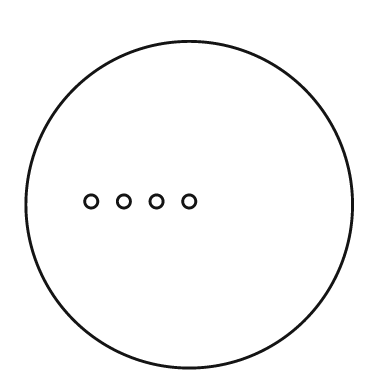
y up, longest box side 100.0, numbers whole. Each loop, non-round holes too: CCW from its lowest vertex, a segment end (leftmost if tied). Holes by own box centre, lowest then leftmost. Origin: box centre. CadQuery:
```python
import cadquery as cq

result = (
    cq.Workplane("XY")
    .moveTo(0.0, 0.0)
    .circle(50.0)
    .moveTo(-30.0, 1.0)
    .circle(2.0)
    .moveTo(-20.0, 1.0)
    .circle(2.0)
    .moveTo(-10.0, 1.0)
    .circle(2.0)
    .moveTo(0.0, 1.0)
    .circle(2.0)
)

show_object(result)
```